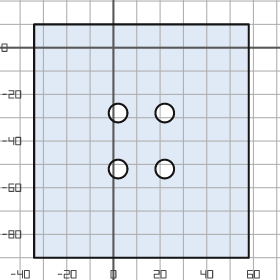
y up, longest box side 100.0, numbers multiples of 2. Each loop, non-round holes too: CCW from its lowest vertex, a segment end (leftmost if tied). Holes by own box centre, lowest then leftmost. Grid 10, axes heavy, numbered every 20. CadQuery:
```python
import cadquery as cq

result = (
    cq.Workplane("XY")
    .moveTo(-34.0, -90.0)
    .lineTo(58.0, -90.0)
    .lineTo(58.0, 10.0)
    .lineTo(-34.0, 10.0)
    .close()
    .moveTo(2.0, -52.0)
    .circle(4.0)
    .moveTo(22.0, -52.0)
    .circle(4.0)
    .moveTo(2.0, -28.0)
    .circle(4.0)
    .moveTo(22.0, -28.0)
    .circle(4.0)
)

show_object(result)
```